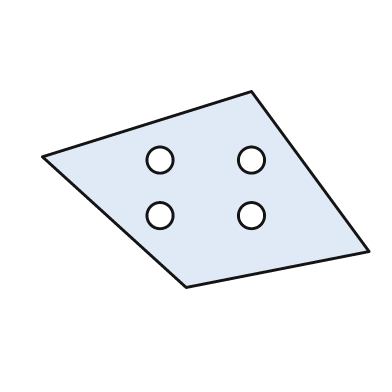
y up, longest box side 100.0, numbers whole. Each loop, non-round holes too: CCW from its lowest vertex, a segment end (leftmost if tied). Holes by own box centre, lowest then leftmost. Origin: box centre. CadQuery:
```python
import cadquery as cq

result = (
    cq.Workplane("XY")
    .moveTo(-6.0, -30.0)
    .lineTo(50.0, -19.0)
    .lineTo(14.0, 30.0)
    .lineTo(-50.0, 10.0)
    .close()
    .moveTo(-14.0, -8.0)
    .circle(4.0)
    .moveTo(14.0, -8.0)
    .circle(4.0)
    .moveTo(-14.0, 9.0)
    .circle(4.0)
    .moveTo(14.0, 9.0)
    .circle(4.0)
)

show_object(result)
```